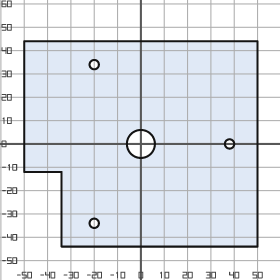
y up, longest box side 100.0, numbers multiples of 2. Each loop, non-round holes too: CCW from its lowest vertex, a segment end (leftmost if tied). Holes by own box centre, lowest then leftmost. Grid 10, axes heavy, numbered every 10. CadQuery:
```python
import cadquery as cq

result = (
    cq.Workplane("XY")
    .moveTo(-34.0, -44.0)
    .lineTo(50.0, -44.0)
    .lineTo(50.0, 44.0)
    .lineTo(-50.0, 44.0)
    .lineTo(-50.0, -12.0)
    .lineTo(-34.0, -12.0)
    .close()
    .moveTo(-20.0, -34.0)
    .circle(2.0)
    .moveTo(0.0, 0.0)
    .circle(6.0)
    .moveTo(38.0, 0.0)
    .circle(2.0)
    .moveTo(-20.0, 34.0)
    .circle(2.0)
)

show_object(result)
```